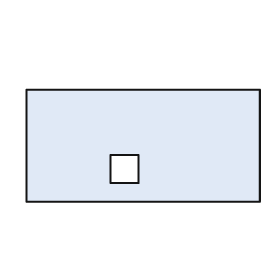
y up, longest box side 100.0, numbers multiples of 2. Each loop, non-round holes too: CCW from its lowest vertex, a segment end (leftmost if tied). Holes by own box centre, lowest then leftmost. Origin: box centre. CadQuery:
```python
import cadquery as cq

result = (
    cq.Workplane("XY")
    .moveTo(-50.0, -24.0)
    .lineTo(50.0, -24.0)
    .lineTo(50.0, 24.0)
    .lineTo(-50.0, 24.0)
    .close()
    .moveTo(-14.0, -16.0)
    .lineTo(-2.0, -16.0)
    .lineTo(-2.0, -4.0)
    .lineTo(-14.0, -4.0)
    .close()
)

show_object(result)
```